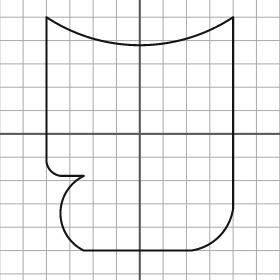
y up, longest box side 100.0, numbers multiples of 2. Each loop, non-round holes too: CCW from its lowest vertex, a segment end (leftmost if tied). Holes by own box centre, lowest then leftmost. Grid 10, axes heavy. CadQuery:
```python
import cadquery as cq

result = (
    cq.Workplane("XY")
    .moveTo(-24.0, -50.0)
    .lineTo(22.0, -50.0)
    .threePointArc((34.0, -44.0), (40.0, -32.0))
    .lineTo(40.0, 50.0)
    .threePointArc((0.0, 38.0), (-40.0, 50.0))
    .lineTo(-40.0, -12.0)
    .threePointArc((-38.0, -16.0), (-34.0, -18.0))
    .lineTo(-24.0, -18.0)
    .threePointArc((-34.0, -34.0), (-24.0, -50.0))
    .close()
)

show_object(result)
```